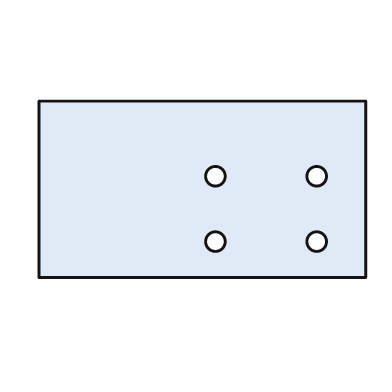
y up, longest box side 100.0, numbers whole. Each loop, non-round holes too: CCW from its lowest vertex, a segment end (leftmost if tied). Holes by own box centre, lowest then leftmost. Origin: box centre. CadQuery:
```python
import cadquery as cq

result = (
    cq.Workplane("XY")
    .moveTo(-50.0, -27.0)
    .lineTo(50.0, -27.0)
    .lineTo(50.0, 27.0)
    .lineTo(-50.0, 27.0)
    .close()
    .moveTo(4.0, -16.0)
    .circle(3.0)
    .moveTo(35.0, -16.0)
    .circle(3.0)
    .moveTo(4.0, 4.0)
    .circle(3.0)
    .moveTo(35.0, 4.0)
    .circle(3.0)
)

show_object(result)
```